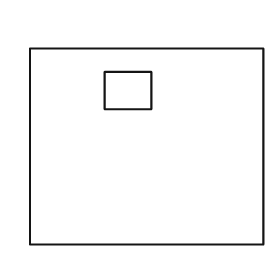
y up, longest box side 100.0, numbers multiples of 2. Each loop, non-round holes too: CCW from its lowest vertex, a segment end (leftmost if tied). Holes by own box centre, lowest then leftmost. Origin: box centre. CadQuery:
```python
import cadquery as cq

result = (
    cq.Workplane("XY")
    .moveTo(-50.0, -42.0)
    .lineTo(50.0, -42.0)
    .lineTo(50.0, 42.0)
    .lineTo(-50.0, 42.0)
    .close()
    .moveTo(-18.0, 16.0)
    .lineTo(2.0, 16.0)
    .lineTo(2.0, 32.0)
    .lineTo(-18.0, 32.0)
    .close()
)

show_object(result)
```